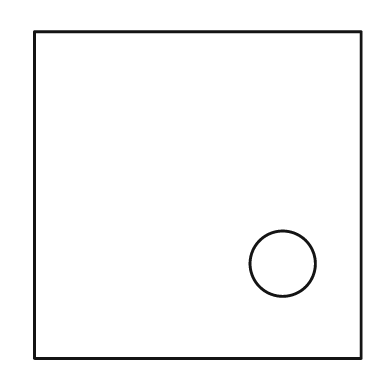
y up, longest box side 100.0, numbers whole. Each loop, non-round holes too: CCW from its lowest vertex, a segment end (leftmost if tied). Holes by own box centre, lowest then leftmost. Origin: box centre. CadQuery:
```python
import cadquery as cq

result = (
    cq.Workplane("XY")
    .moveTo(-50.0, -50.0)
    .lineTo(50.0, -50.0)
    .lineTo(50.0, 50.0)
    .lineTo(-50.0, 50.0)
    .close()
    .moveTo(26.0, -21.0)
    .circle(10.0)
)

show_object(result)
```